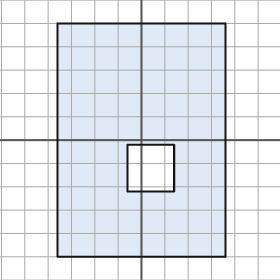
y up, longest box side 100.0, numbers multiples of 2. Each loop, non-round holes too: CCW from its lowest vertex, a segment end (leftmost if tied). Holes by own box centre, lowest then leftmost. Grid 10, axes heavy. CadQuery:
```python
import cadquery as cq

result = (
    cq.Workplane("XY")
    .moveTo(-36.0, -50.0)
    .lineTo(36.0, -50.0)
    .lineTo(36.0, 50.0)
    .lineTo(-36.0, 50.0)
    .close()
    .moveTo(-6.0, -22.0)
    .lineTo(14.0, -22.0)
    .lineTo(14.0, -2.0)
    .lineTo(-6.0, -2.0)
    .close()
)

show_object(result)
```